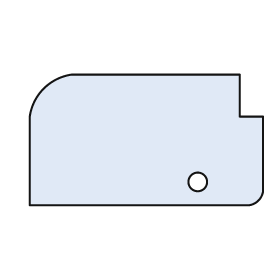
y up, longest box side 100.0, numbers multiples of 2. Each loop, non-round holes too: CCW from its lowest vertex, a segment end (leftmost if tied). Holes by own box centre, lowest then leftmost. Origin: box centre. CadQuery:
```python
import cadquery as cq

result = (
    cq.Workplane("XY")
    .moveTo(-50.0, -28.0)
    .lineTo(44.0, -28.0)
    .threePointArc((48.0, -26.0), (50.0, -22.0))
    .lineTo(50.0, 10.0)
    .lineTo(40.0, 10.0)
    .lineTo(40.0, 28.0)
    .lineTo(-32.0, 28.0)
    .threePointArc((-44.0, 22.0), (-50.0, 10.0))
    .close()
    .moveTo(22.0, -18.0)
    .circle(4.0)
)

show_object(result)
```